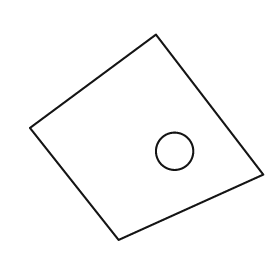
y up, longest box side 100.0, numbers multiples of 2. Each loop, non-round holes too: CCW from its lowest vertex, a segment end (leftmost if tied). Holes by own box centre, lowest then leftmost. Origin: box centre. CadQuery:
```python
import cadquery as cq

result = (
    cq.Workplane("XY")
    .moveTo(-12.0, -44.0)
    .lineTo(50.0, -16.0)
    .lineTo(4.0, 44.0)
    .lineTo(-50.0, 4.0)
    .close()
    .moveTo(12.0, -6.0)
    .circle(8.0)
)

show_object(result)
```